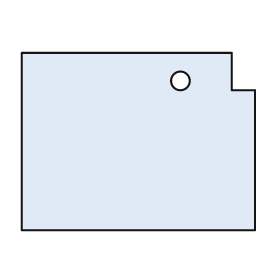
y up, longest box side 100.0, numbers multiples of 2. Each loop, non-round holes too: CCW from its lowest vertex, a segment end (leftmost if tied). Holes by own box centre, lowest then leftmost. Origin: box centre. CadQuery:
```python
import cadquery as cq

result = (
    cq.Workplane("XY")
    .moveTo(-50.0, -38.0)
    .lineTo(50.0, -38.0)
    .lineTo(50.0, 22.0)
    .lineTo(40.0, 22.0)
    .lineTo(40.0, 38.0)
    .lineTo(-50.0, 38.0)
    .close()
    .moveTo(18.0, 26.0)
    .circle(4.0)
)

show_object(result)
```